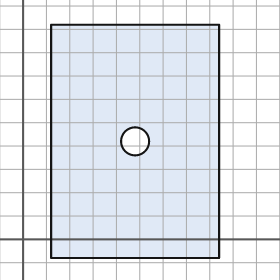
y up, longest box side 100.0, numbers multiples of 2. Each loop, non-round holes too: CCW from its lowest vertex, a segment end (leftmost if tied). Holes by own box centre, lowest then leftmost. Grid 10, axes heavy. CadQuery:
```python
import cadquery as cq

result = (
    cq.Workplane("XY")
    .moveTo(12.0, -8.0)
    .lineTo(84.0, -8.0)
    .lineTo(84.0, 92.0)
    .lineTo(12.0, 92.0)
    .close()
    .moveTo(48.0, 42.0)
    .circle(6.0)
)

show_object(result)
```